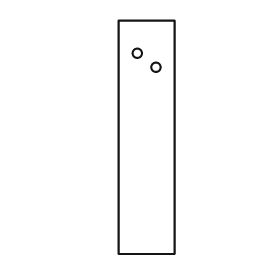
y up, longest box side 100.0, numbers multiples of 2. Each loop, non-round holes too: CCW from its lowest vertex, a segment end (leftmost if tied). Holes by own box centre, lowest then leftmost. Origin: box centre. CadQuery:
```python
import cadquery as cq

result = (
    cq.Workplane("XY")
    .moveTo(-12.0, -50.0)
    .lineTo(12.0, -50.0)
    .lineTo(12.0, 50.0)
    .lineTo(-12.0, 50.0)
    .close()
    .moveTo(4.0, 30.0)
    .circle(2.0)
    .moveTo(-4.0, 36.0)
    .circle(2.0)
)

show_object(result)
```